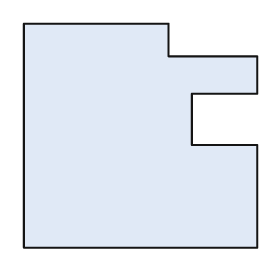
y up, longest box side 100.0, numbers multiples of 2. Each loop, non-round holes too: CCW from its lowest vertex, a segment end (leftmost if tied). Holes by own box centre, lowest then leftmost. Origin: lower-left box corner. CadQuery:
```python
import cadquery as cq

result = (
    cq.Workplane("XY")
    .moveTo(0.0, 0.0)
    .lineTo(100.0, 0.0)
    .lineTo(100.0, 44.0)
    .lineTo(72.0, 44.0)
    .lineTo(72.0, 66.0)
    .lineTo(100.0, 66.0)
    .lineTo(100.0, 82.0)
    .lineTo(62.0, 82.0)
    .lineTo(62.0, 96.0)
    .lineTo(0.0, 96.0)
    .close()
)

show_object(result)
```